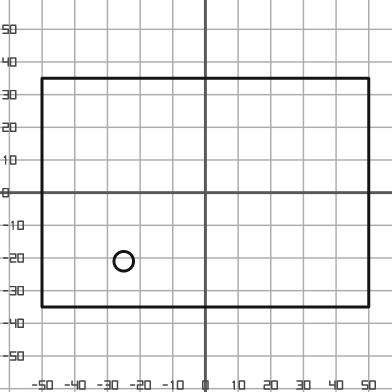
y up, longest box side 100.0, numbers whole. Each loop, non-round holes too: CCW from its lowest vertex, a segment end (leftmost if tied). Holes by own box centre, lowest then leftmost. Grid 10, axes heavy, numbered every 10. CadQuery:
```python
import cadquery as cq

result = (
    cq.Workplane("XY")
    .moveTo(-50.0, -35.0)
    .lineTo(50.0, -35.0)
    .lineTo(50.0, 35.0)
    .lineTo(-50.0, 35.0)
    .close()
    .moveTo(-25.0, -21.0)
    .circle(3.0)
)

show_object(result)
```